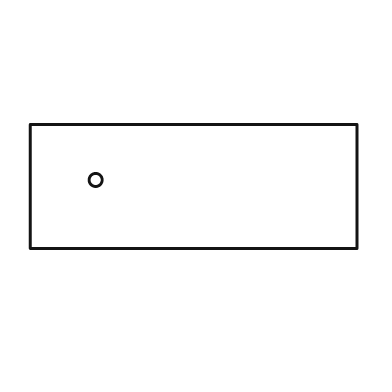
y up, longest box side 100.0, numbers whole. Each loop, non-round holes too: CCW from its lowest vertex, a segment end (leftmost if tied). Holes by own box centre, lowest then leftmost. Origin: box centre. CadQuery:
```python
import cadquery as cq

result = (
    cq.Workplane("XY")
    .moveTo(-50.0, -19.0)
    .lineTo(50.0, -19.0)
    .lineTo(50.0, 19.0)
    .lineTo(-50.0, 19.0)
    .close()
    .moveTo(-30.0, 2.0)
    .circle(2.0)
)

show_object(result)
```